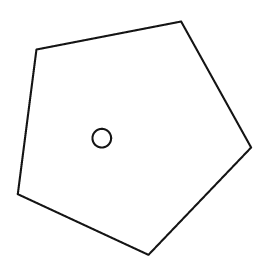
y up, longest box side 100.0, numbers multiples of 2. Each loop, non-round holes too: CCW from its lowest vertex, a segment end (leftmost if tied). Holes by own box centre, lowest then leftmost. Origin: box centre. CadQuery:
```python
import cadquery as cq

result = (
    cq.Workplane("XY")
    .moveTo(6.0, -50.0)
    .lineTo(50.0, -4.0)
    .lineTo(20.0, 50.0)
    .lineTo(-42.0, 38.0)
    .lineTo(-50.0, -24.0)
    .close()
    .moveTo(-14.0, 0.0)
    .circle(4.0)
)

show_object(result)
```